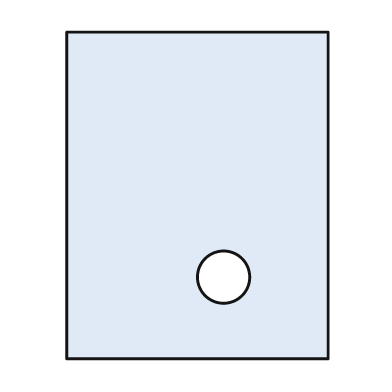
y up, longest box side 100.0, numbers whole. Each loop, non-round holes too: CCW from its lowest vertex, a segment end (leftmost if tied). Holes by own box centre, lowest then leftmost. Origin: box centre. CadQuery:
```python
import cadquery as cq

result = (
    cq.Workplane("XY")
    .moveTo(-40.0, -50.0)
    .lineTo(40.0, -50.0)
    .lineTo(40.0, 50.0)
    .lineTo(-40.0, 50.0)
    .close()
    .moveTo(8.0, -25.0)
    .circle(8.0)
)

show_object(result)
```